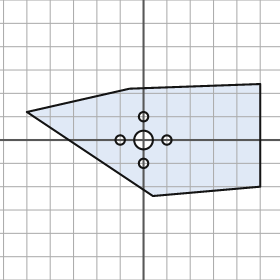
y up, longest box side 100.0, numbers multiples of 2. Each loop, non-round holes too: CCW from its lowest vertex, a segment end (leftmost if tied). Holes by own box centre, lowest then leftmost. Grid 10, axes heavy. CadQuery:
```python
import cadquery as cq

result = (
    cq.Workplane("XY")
    .moveTo(4.0, -24.0)
    .lineTo(50.0, -20.0)
    .lineTo(50.0, 24.0)
    .lineTo(-6.0, 22.0)
    .lineTo(-50.0, 12.0)
    .close()
    .moveTo(0.0, -10.0)
    .circle(2.0)
    .moveTo(-10.0, 0.0)
    .circle(2.0)
    .moveTo(0.0, 0.0)
    .circle(4.0)
    .moveTo(10.0, 0.0)
    .circle(2.0)
    .moveTo(0.0, 10.0)
    .circle(2.0)
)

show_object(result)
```